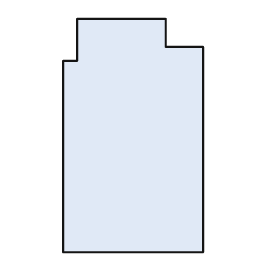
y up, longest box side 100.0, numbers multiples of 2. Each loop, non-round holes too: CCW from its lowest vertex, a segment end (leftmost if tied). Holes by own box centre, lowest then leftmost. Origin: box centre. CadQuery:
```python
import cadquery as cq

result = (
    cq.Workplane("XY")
    .moveTo(-30.0, -50.0)
    .lineTo(30.0, -50.0)
    .lineTo(30.0, 38.0)
    .lineTo(14.0, 38.0)
    .lineTo(14.0, 50.0)
    .lineTo(-24.0, 50.0)
    .lineTo(-24.0, 32.0)
    .lineTo(-30.0, 32.0)
    .close()
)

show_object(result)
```